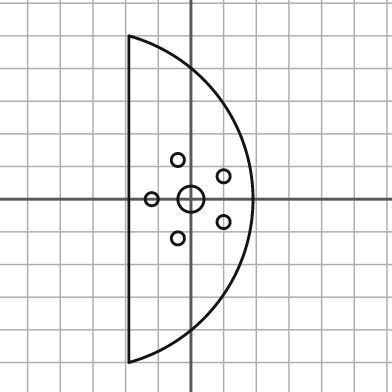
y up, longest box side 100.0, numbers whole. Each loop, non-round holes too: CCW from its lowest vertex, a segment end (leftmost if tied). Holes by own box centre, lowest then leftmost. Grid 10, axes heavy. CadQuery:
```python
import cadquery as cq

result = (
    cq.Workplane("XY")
    .moveTo(-19.0, -50.0)
    .threePointArc((19.0, 0.0), (-19.0, 50.0))
    .close()
    .moveTo(-4.0, -12.0)
    .circle(2.0)
    .moveTo(10.0, -7.0)
    .circle(2.0)
    .moveTo(-12.0, 0.0)
    .circle(2.0)
    .moveTo(0.0, 0.0)
    .circle(4.0)
    .moveTo(10.0, 7.0)
    .circle(2.0)
    .moveTo(-4.0, 12.0)
    .circle(2.0)
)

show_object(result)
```